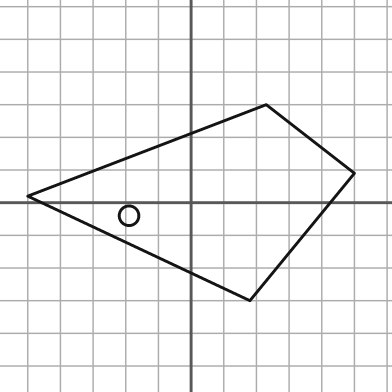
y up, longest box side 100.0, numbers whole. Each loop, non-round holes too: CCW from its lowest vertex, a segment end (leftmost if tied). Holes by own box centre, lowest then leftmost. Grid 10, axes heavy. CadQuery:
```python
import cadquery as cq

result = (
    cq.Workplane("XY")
    .moveTo(18.0, -30.0)
    .lineTo(50.0, 9.0)
    .lineTo(23.0, 30.0)
    .lineTo(-50.0, 2.0)
    .close()
    .moveTo(-19.0, -4.0)
    .circle(3.0)
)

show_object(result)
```